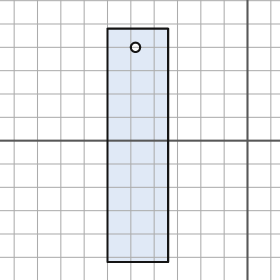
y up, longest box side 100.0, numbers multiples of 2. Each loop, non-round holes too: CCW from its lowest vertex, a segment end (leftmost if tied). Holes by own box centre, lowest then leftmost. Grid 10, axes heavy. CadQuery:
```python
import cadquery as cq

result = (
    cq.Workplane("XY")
    .moveTo(-60.0, -52.0)
    .lineTo(-34.0, -52.0)
    .lineTo(-34.0, 48.0)
    .lineTo(-60.0, 48.0)
    .close()
    .moveTo(-48.0, 40.0)
    .circle(2.0)
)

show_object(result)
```